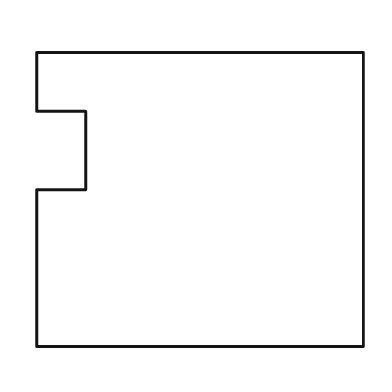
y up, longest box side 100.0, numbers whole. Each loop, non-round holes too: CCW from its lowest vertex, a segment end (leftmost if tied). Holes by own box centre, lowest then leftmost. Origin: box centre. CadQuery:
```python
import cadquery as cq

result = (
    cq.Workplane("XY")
    .moveTo(-50.0, -45.0)
    .lineTo(50.0, -45.0)
    .lineTo(50.0, 45.0)
    .lineTo(-50.0, 45.0)
    .lineTo(-50.0, 27.0)
    .lineTo(-35.0, 27.0)
    .lineTo(-35.0, 3.0)
    .lineTo(-50.0, 3.0)
    .close()
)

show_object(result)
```